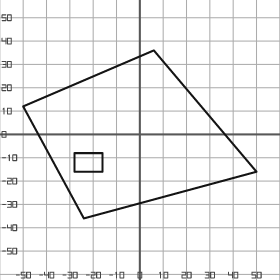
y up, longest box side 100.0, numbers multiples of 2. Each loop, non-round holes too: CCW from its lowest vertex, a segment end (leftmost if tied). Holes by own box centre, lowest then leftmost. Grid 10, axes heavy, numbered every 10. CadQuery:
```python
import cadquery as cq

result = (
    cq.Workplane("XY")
    .moveTo(-24.0, -36.0)
    .lineTo(50.0, -16.0)
    .lineTo(6.0, 36.0)
    .lineTo(-50.0, 12.0)
    .close()
    .moveTo(-28.0, -16.0)
    .lineTo(-16.0, -16.0)
    .lineTo(-16.0, -8.0)
    .lineTo(-28.0, -8.0)
    .close()
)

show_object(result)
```